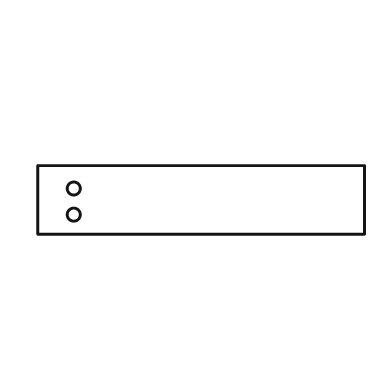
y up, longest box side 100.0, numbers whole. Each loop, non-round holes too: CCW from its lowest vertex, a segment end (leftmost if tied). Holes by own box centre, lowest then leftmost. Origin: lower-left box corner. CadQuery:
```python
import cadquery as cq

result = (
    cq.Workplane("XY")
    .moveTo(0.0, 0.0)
    .lineTo(100.0, 0.0)
    .lineTo(100.0, 21.0)
    .lineTo(0.0, 21.0)
    .close()
    .moveTo(11.0, 6.0)
    .circle(2.0)
    .moveTo(11.0, 14.0)
    .circle(2.0)
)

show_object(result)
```